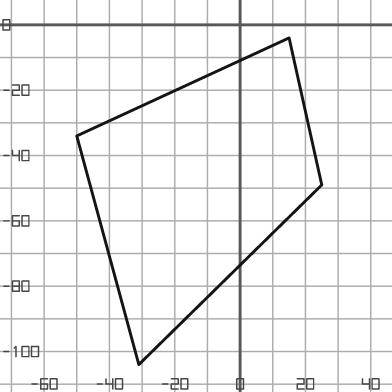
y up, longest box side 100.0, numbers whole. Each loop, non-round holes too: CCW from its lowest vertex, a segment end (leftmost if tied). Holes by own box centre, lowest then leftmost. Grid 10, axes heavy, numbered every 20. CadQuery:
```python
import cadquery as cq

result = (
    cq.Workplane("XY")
    .moveTo(-31.0, -104.0)
    .lineTo(25.0, -49.0)
    .lineTo(15.0, -4.0)
    .lineTo(-50.0, -34.0)
    .close()
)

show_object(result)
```